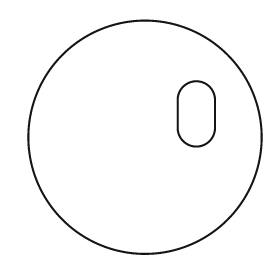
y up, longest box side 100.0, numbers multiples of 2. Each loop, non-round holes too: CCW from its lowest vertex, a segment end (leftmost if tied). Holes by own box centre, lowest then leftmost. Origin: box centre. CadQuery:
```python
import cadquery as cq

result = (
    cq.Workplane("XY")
    .moveTo(0.0, 0.0)
    .circle(50.0)
    .moveTo(14.0, 4.0)
    .threePointArc((22.0, -4.0), (30.0, 4.0))
    .lineTo(30.0, 16.0)
    .threePointArc((22.0, 24.0), (14.0, 16.0))
    .close()
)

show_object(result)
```